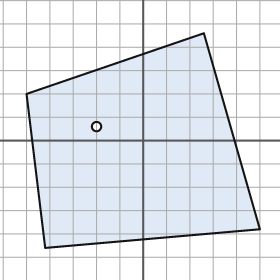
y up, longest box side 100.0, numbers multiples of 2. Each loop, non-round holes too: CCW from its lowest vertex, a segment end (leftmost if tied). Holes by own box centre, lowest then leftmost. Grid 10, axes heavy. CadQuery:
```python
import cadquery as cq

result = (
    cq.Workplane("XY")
    .moveTo(-42.0, -46.0)
    .lineTo(50.0, -38.0)
    .lineTo(26.0, 46.0)
    .lineTo(-50.0, 20.0)
    .close()
    .moveTo(-20.0, 6.0)
    .circle(2.0)
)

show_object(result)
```